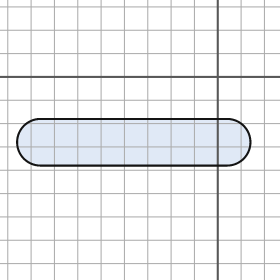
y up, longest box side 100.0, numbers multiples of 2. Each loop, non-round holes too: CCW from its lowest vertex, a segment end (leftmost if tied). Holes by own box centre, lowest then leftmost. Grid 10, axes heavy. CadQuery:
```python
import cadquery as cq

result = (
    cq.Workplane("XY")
    .moveTo(-76.0, -38.0)
    .lineTo(4.0, -38.0)
    .threePointArc((14.0, -28.0), (4.0, -18.0))
    .lineTo(-76.0, -18.0)
    .threePointArc((-86.0, -28.0), (-76.0, -38.0))
    .close()
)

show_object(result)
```